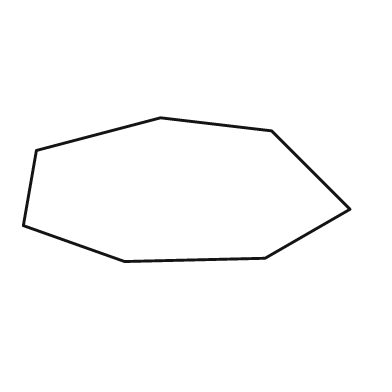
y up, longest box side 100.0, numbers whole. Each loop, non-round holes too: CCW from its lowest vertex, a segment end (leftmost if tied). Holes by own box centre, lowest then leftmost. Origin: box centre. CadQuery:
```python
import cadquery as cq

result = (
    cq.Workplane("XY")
    .moveTo(-19.0, -22.0)
    .lineTo(24.0, -21.0)
    .lineTo(50.0, -6.0)
    .lineTo(26.0, 18.0)
    .lineTo(-8.0, 22.0)
    .lineTo(-46.0, 12.0)
    .lineTo(-50.0, -11.0)
    .close()
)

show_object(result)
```